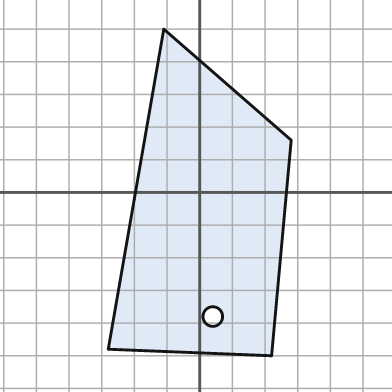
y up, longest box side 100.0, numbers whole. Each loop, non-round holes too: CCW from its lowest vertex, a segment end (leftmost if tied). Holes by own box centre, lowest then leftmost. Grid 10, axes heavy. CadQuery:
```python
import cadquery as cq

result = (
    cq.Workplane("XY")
    .moveTo(22.0, -50.0)
    .lineTo(28.0, 16.0)
    .lineTo(-11.0, 50.0)
    .lineTo(-28.0, -48.0)
    .close()
    .moveTo(4.0, -38.0)
    .circle(3.0)
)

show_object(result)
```